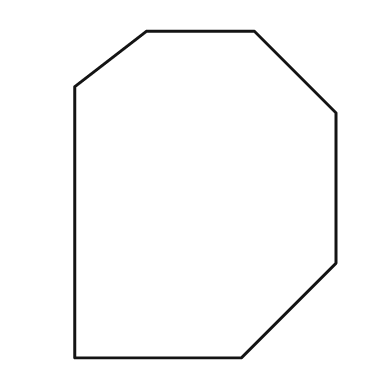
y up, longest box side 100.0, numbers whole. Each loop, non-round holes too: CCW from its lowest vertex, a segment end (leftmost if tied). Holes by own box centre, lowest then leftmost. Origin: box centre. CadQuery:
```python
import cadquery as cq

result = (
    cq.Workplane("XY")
    .moveTo(-40.0, -50.0)
    .lineTo(11.0, -50.0)
    .lineTo(40.0, -21.0)
    .lineTo(40.0, 25.0)
    .lineTo(15.0, 50.0)
    .lineTo(-18.0, 50.0)
    .lineTo(-40.0, 33.0)
    .close()
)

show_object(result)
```